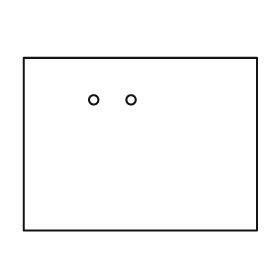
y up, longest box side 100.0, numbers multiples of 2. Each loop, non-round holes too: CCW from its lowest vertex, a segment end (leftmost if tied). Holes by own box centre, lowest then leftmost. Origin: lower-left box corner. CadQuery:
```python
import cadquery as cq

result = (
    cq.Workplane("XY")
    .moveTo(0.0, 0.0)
    .lineTo(100.0, 0.0)
    .lineTo(100.0, 74.0)
    .lineTo(0.0, 74.0)
    .close()
    .moveTo(30.0, 56.0)
    .circle(2.0)
    .moveTo(46.0, 56.0)
    .circle(2.0)
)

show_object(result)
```